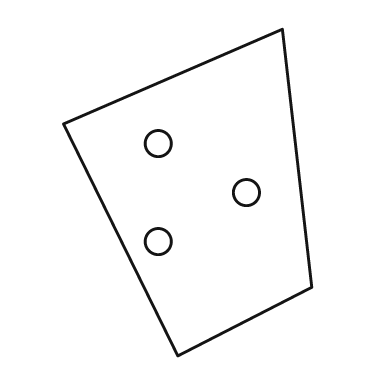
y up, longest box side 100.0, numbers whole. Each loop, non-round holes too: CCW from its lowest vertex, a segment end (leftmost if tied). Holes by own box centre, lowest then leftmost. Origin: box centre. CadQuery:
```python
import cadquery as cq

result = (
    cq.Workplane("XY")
    .moveTo(-3.0, -50.0)
    .lineTo(38.0, -29.0)
    .lineTo(29.0, 50.0)
    .lineTo(-38.0, 21.0)
    .close()
    .moveTo(-9.0, -15.0)
    .circle(4.0)
    .moveTo(18.0, 0.0)
    .circle(4.0)
    .moveTo(-9.0, 15.0)
    .circle(4.0)
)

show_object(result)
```